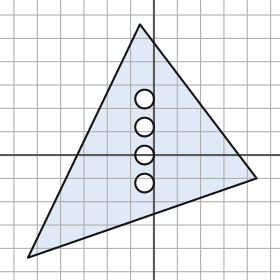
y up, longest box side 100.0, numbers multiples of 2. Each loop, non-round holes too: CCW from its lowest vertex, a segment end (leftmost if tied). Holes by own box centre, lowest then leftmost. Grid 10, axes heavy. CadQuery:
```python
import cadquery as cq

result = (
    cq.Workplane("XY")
    .moveTo(-54.0, -44.0)
    .lineTo(44.0, -10.0)
    .lineTo(-6.0, 56.0)
    .close()
    .moveTo(-4.0, -12.0)
    .circle(4.0)
    .moveTo(-4.0, 0.0)
    .circle(4.0)
    .moveTo(-4.0, 12.0)
    .circle(4.0)
    .moveTo(-4.0, 24.0)
    .circle(4.0)
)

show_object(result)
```